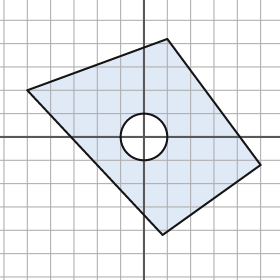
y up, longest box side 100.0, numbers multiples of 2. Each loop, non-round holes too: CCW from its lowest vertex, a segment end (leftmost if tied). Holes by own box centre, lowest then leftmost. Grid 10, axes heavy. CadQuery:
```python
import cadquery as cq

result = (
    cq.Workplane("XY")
    .moveTo(8.0, -42.0)
    .lineTo(50.0, -12.0)
    .lineTo(10.0, 42.0)
    .lineTo(-50.0, 20.0)
    .close()
    .moveTo(0.0, 0.0)
    .circle(10.0)
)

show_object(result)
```